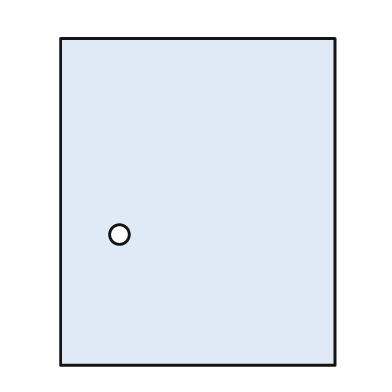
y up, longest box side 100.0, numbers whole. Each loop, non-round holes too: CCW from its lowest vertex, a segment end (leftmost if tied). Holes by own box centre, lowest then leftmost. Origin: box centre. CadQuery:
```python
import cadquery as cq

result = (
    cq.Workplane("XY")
    .moveTo(-42.0, -50.0)
    .lineTo(42.0, -50.0)
    .lineTo(42.0, 50.0)
    .lineTo(-42.0, 50.0)
    .close()
    .moveTo(-24.0, -10.0)
    .circle(3.0)
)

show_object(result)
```